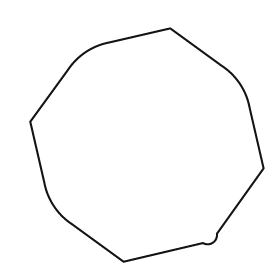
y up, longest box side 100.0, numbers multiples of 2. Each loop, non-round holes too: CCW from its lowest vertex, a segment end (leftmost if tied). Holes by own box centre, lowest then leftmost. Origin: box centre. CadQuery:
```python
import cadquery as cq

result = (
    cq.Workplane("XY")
    .moveTo(-10.0, -50.0)
    .lineTo(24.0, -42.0)
    .threePointArc((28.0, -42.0), (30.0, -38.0))
    .lineTo(50.0, -10.0)
    .lineTo(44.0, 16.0)
    .threePointArc((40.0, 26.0), (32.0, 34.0))
    .lineTo(10.0, 50.0)
    .lineTo(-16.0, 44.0)
    .threePointArc((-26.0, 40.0), (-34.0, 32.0))
    .lineTo(-50.0, 10.0)
    .lineTo(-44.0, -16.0)
    .threePointArc((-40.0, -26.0), (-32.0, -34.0))
    .close()
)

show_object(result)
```